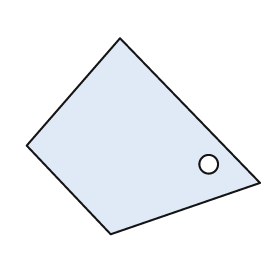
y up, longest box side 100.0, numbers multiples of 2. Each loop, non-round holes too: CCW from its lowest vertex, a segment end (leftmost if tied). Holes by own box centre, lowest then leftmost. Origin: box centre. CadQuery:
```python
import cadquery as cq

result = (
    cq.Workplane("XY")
    .moveTo(-14.0, -42.0)
    .lineTo(50.0, -20.0)
    .lineTo(-10.0, 42.0)
    .lineTo(-50.0, -4.0)
    .close()
    .moveTo(28.0, -12.0)
    .circle(4.0)
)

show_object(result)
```